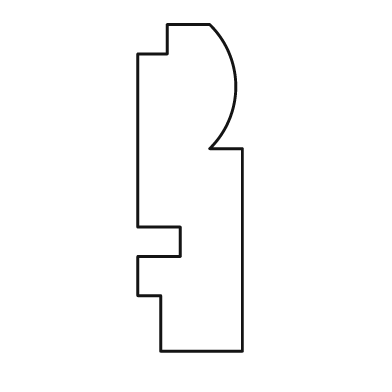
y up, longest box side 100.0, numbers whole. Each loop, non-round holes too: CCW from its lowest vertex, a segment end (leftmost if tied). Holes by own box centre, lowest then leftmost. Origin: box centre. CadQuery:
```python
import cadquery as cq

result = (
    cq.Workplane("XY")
    .moveTo(-9.0, -50.0)
    .lineTo(16.0, -50.0)
    .lineTo(16.0, 12.0)
    .lineTo(6.0, 12.0)
    .threePointArc((14.0, 31.0), (6.0, 50.0))
    .lineTo(-7.0, 50.0)
    .lineTo(-7.0, 41.0)
    .lineTo(-16.0, 41.0)
    .lineTo(-16.0, -12.0)
    .lineTo(-3.0, -12.0)
    .lineTo(-3.0, -21.0)
    .lineTo(-16.0, -21.0)
    .lineTo(-16.0, -33.0)
    .lineTo(-9.0, -33.0)
    .close()
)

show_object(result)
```